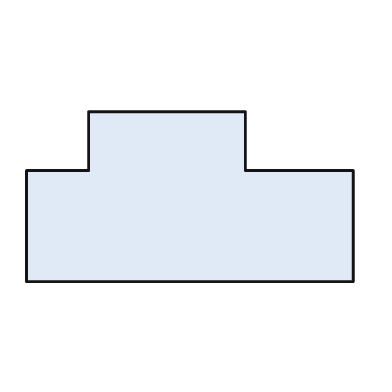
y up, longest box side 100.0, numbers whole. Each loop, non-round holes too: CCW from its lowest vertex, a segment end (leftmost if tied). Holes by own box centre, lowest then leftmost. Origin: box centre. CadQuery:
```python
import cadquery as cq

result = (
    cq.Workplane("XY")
    .moveTo(-50.0, -26.0)
    .lineTo(50.0, -26.0)
    .lineTo(50.0, 8.0)
    .lineTo(17.0, 8.0)
    .lineTo(17.0, 26.0)
    .lineTo(-31.0, 26.0)
    .lineTo(-31.0, 8.0)
    .lineTo(-50.0, 8.0)
    .close()
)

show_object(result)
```